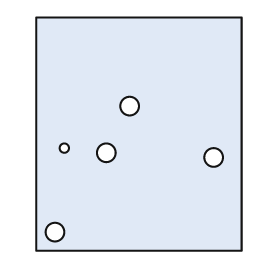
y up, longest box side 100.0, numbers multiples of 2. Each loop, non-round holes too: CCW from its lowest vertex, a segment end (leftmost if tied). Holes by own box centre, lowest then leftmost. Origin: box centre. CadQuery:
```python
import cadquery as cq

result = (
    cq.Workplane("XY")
    .moveTo(-44.0, -50.0)
    .lineTo(44.0, -50.0)
    .lineTo(44.0, 50.0)
    .lineTo(-44.0, 50.0)
    .close()
    .moveTo(-36.0, -42.0)
    .circle(4.0)
    .moveTo(32.0, -10.0)
    .circle(4.0)
    .moveTo(-14.0, -8.0)
    .circle(4.0)
    .moveTo(-32.0, -6.0)
    .circle(2.0)
    .moveTo(-4.0, 12.0)
    .circle(4.0)
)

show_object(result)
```